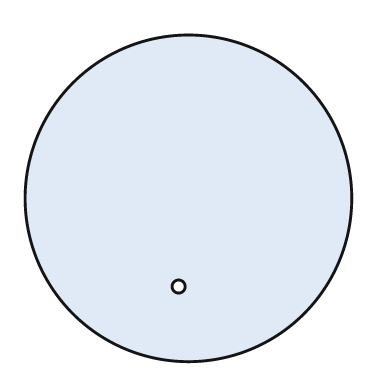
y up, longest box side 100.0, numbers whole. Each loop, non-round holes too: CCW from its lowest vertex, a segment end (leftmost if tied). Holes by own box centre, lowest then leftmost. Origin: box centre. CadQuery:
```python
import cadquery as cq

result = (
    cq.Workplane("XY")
    .moveTo(0.0, 0.0)
    .circle(50.0)
    .moveTo(-3.0, -27.0)
    .circle(2.0)
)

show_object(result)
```